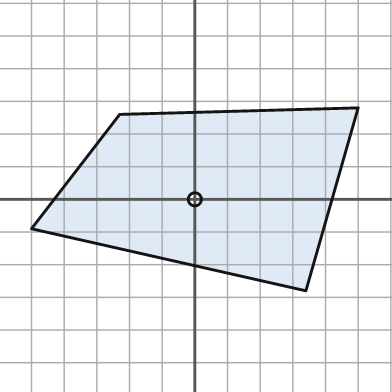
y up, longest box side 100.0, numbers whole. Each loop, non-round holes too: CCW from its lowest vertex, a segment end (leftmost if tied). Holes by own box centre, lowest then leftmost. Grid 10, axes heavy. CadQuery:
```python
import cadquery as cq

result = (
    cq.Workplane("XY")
    .moveTo(34.0, -28.0)
    .lineTo(50.0, 28.0)
    .lineTo(-23.0, 26.0)
    .lineTo(-50.0, -9.0)
    .close()
    .moveTo(0.0, 0.0)
    .circle(2.0)
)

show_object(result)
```